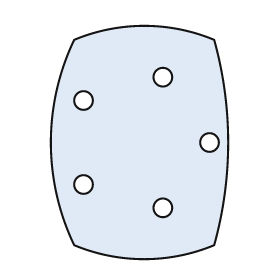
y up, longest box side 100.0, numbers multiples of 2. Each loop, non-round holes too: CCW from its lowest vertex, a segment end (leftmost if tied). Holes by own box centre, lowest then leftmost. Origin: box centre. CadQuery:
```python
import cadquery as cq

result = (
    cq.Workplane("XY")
    .moveTo(-28.0, -44.0)
    .threePointArc((2.0, -50.0), (32.0, -44.0))
    .threePointArc((38.0, 0.0), (32.0, 44.0))
    .threePointArc((2.0, 50.0), (-28.0, 44.0))
    .threePointArc((-38.0, 0.0), (-28.0, -44.0))
    .close()
    .moveTo(10.0, -28.0)
    .circle(4.0)
    .moveTo(-24.0, -18.0)
    .circle(4.0)
    .moveTo(30.0, 0.0)
    .circle(4.0)
    .moveTo(-24.0, 18.0)
    .circle(4.0)
    .moveTo(10.0, 28.0)
    .circle(4.0)
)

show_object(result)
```